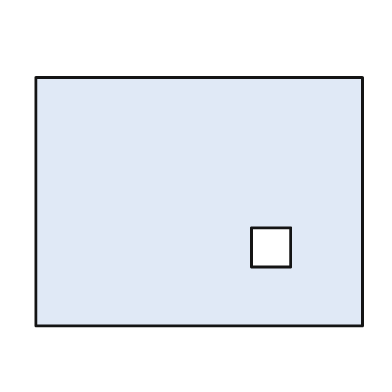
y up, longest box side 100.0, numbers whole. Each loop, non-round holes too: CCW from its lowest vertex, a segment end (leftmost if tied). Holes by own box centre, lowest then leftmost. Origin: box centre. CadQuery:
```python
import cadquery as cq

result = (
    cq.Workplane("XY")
    .moveTo(-50.0, -38.0)
    .lineTo(50.0, -38.0)
    .lineTo(50.0, 38.0)
    .lineTo(-50.0, 38.0)
    .close()
    .moveTo(16.0, -20.0)
    .lineTo(28.0, -20.0)
    .lineTo(28.0, -8.0)
    .lineTo(16.0, -8.0)
    .close()
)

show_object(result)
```